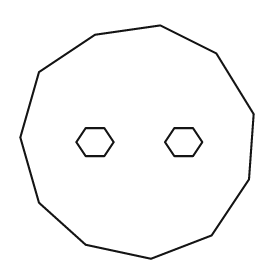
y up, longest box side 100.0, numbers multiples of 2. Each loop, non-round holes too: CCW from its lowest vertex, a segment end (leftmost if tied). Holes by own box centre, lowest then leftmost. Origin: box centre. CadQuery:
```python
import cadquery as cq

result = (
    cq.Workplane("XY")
    .moveTo(6.0, -50.0)
    .lineTo(32.0, -40.0)
    .lineTo(48.0, -16.0)
    .lineTo(50.0, 12.0)
    .lineTo(34.0, 38.0)
    .lineTo(10.0, 50.0)
    .lineTo(-18.0, 46.0)
    .lineTo(-42.0, 30.0)
    .lineTo(-50.0, 2.0)
    .lineTo(-42.0, -26.0)
    .lineTo(-22.0, -44.0)
    .close()
    .moveTo(-22.0, -6.0)
    .lineTo(-14.0, -6.0)
    .lineTo(-10.0, 0.0)
    .lineTo(-14.0, 6.0)
    .lineTo(-22.0, 6.0)
    .lineTo(-26.0, 0.0)
    .close()
    .moveTo(16.0, -6.0)
    .lineTo(24.0, -6.0)
    .lineTo(28.0, 0.0)
    .lineTo(24.0, 6.0)
    .lineTo(16.0, 6.0)
    .lineTo(12.0, 0.0)
    .close()
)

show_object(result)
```